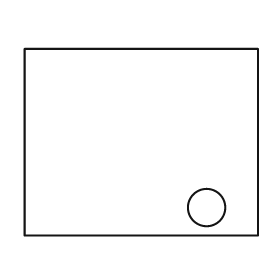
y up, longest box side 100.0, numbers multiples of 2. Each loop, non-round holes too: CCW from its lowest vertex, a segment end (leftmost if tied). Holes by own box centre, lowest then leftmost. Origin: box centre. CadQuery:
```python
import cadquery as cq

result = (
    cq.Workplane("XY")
    .moveTo(-50.0, -40.0)
    .lineTo(50.0, -40.0)
    .lineTo(50.0, 40.0)
    .lineTo(-50.0, 40.0)
    .close()
    .moveTo(28.0, -28.0)
    .circle(8.0)
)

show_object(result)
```